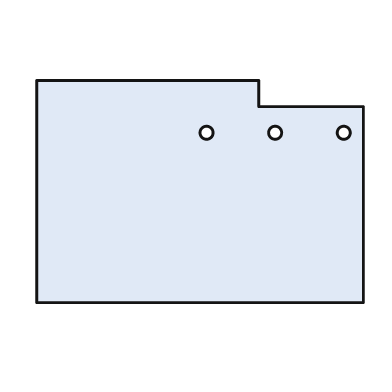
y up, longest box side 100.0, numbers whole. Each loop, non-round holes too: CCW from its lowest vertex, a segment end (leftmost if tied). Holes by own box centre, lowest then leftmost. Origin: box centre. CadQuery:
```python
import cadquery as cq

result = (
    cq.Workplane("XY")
    .moveTo(-50.0, -34.0)
    .lineTo(50.0, -34.0)
    .lineTo(50.0, 26.0)
    .lineTo(18.0, 26.0)
    .lineTo(18.0, 34.0)
    .lineTo(-50.0, 34.0)
    .close()
    .moveTo(2.0, 18.0)
    .circle(2.0)
    .moveTo(23.0, 18.0)
    .circle(2.0)
    .moveTo(44.0, 18.0)
    .circle(2.0)
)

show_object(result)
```